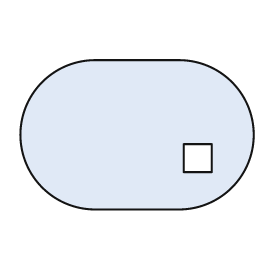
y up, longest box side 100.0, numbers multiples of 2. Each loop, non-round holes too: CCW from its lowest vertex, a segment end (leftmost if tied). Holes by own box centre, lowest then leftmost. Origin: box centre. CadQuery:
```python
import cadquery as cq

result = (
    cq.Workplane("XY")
    .moveTo(-18.0, -32.0)
    .lineTo(18.0, -32.0)
    .threePointArc((50.0, 0.0), (18.0, 32.0))
    .lineTo(-18.0, 32.0)
    .threePointArc((-50.0, 0.0), (-18.0, -32.0))
    .close()
    .moveTo(20.0, -16.0)
    .lineTo(32.0, -16.0)
    .lineTo(32.0, -4.0)
    .lineTo(20.0, -4.0)
    .close()
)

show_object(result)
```